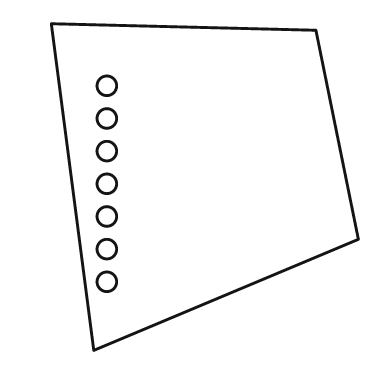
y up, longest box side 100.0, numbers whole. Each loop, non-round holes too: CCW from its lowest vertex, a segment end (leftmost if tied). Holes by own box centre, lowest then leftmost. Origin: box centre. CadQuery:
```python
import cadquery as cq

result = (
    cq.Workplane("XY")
    .moveTo(-34.0, -50.0)
    .lineTo(47.0, -16.0)
    .lineTo(34.0, 48.0)
    .lineTo(-47.0, 50.0)
    .close()
    .moveTo(-30.0, -29.0)
    .circle(3.0)
    .moveTo(-30.0, -19.0)
    .circle(3.0)
    .moveTo(-30.0, -9.0)
    .circle(3.0)
    .moveTo(-30.0, 1.0)
    .circle(3.0)
    .moveTo(-30.0, 11.0)
    .circle(3.0)
    .moveTo(-30.0, 21.0)
    .circle(3.0)
    .moveTo(-30.0, 31.0)
    .circle(3.0)
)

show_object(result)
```